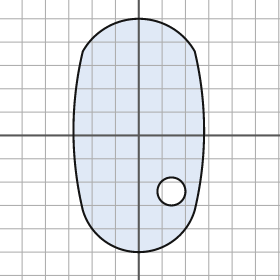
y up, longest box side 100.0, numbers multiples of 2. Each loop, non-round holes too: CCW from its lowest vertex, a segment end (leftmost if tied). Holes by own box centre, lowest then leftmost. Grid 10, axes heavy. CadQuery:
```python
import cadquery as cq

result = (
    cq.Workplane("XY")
    .moveTo(-24.0, -32.0)
    .threePointArc((0.0, -50.0), (24.0, -32.0))
    .threePointArc((28.0, 2.0), (24.0, 36.0))
    .threePointArc((0.0, 50.0), (-24.0, 36.0))
    .threePointArc((-28.0, 2.0), (-24.0, -32.0))
    .close()
    .moveTo(14.0, -24.0)
    .circle(6.0)
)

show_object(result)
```